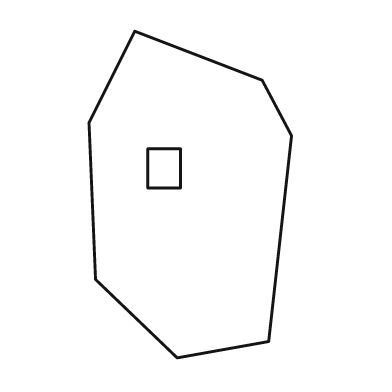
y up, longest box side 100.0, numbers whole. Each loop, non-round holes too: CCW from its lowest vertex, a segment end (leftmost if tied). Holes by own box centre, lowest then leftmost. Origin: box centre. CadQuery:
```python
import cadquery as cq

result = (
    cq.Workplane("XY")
    .moveTo(-4.0, -50.0)
    .lineTo(24.0, -45.0)
    .lineTo(31.0, 18.0)
    .lineTo(22.0, 35.0)
    .lineTo(-17.0, 50.0)
    .lineTo(-31.0, 22.0)
    .lineTo(-29.0, -26.0)
    .close()
    .moveTo(-13.0, 2.0)
    .lineTo(-3.0, 2.0)
    .lineTo(-3.0, 14.0)
    .lineTo(-13.0, 14.0)
    .close()
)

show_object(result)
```